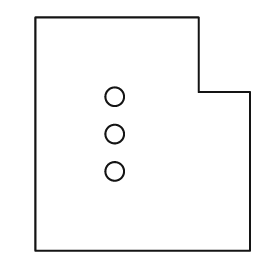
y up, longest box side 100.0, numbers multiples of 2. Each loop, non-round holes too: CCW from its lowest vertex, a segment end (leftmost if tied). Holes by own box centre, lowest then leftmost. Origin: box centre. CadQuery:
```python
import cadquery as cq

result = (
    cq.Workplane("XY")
    .moveTo(-46.0, -50.0)
    .lineTo(46.0, -50.0)
    .lineTo(46.0, 18.0)
    .lineTo(24.0, 18.0)
    .lineTo(24.0, 50.0)
    .lineTo(-46.0, 50.0)
    .close()
    .moveTo(-12.0, -16.0)
    .circle(4.0)
    .moveTo(-12.0, 0.0)
    .circle(4.0)
    .moveTo(-12.0, 16.0)
    .circle(4.0)
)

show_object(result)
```